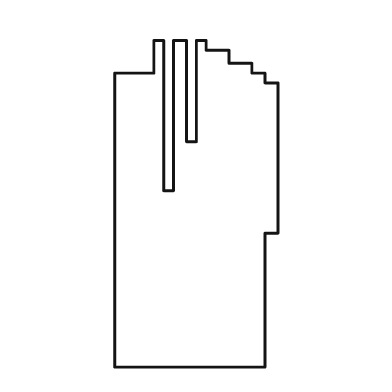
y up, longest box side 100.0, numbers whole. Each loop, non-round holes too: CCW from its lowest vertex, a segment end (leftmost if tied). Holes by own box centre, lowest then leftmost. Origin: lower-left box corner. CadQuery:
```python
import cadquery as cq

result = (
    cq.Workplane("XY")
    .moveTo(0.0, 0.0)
    .lineTo(46.0, 0.0)
    .lineTo(46.0, 41.0)
    .lineTo(50.0, 41.0)
    .lineTo(50.0, 87.0)
    .lineTo(46.0, 87.0)
    .lineTo(46.0, 90.0)
    .lineTo(42.0, 90.0)
    .lineTo(42.0, 93.0)
    .lineTo(35.0, 93.0)
    .lineTo(35.0, 97.0)
    .lineTo(28.0, 97.0)
    .lineTo(28.0, 100.0)
    .lineTo(25.0, 100.0)
    .lineTo(25.0, 69.0)
    .lineTo(22.0, 69.0)
    .lineTo(22.0, 100.0)
    .lineTo(18.0, 100.0)
    .lineTo(18.0, 54.0)
    .lineTo(15.0, 54.0)
    .lineTo(15.0, 100.0)
    .lineTo(12.0, 100.0)
    .lineTo(12.0, 90.0)
    .lineTo(0.0, 90.0)
    .close()
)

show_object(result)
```